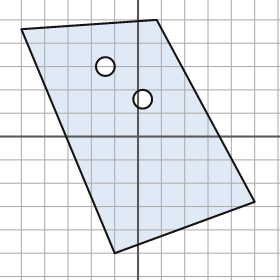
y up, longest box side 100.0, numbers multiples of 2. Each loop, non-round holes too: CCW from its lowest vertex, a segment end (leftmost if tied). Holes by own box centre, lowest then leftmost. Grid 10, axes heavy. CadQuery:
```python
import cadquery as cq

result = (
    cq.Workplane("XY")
    .moveTo(-10.0, -50.0)
    .lineTo(50.0, -28.0)
    .lineTo(8.0, 50.0)
    .lineTo(-50.0, 46.0)
    .close()
    .moveTo(2.0, 16.0)
    .circle(4.0)
    .moveTo(-14.0, 30.0)
    .circle(4.0)
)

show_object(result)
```